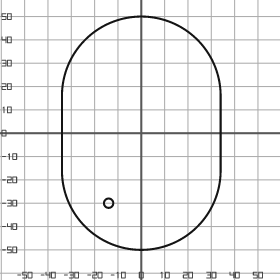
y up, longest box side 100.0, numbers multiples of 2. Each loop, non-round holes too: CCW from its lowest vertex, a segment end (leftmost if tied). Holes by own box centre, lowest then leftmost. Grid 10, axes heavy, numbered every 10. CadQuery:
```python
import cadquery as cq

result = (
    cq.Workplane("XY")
    .moveTo(-34.0, -16.0)
    .threePointArc((0.0, -50.0), (34.0, -16.0))
    .lineTo(34.0, 16.0)
    .threePointArc((0.0, 50.0), (-34.0, 16.0))
    .close()
    .moveTo(-14.0, -30.0)
    .circle(2.0)
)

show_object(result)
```